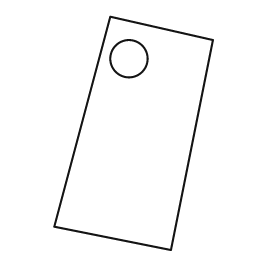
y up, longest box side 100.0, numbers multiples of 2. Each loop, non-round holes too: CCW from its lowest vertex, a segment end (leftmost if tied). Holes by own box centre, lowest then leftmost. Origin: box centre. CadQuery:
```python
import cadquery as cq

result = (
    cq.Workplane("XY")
    .moveTo(16.0, -50.0)
    .lineTo(34.0, 40.0)
    .lineTo(-10.0, 50.0)
    .lineTo(-34.0, -40.0)
    .close()
    .moveTo(-2.0, 32.0)
    .circle(8.0)
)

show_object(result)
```